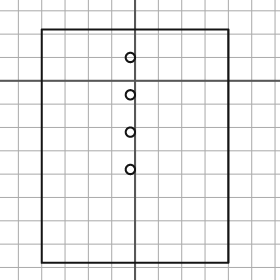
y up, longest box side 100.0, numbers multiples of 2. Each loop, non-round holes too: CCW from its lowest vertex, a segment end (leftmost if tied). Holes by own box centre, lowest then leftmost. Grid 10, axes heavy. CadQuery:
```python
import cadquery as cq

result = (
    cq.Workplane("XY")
    .moveTo(-40.0, -78.0)
    .lineTo(40.0, -78.0)
    .lineTo(40.0, 22.0)
    .lineTo(-40.0, 22.0)
    .close()
    .moveTo(-2.0, -38.0)
    .circle(2.0)
    .moveTo(-2.0, -22.0)
    .circle(2.0)
    .moveTo(-2.0, -6.0)
    .circle(2.0)
    .moveTo(-2.0, 10.0)
    .circle(2.0)
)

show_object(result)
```